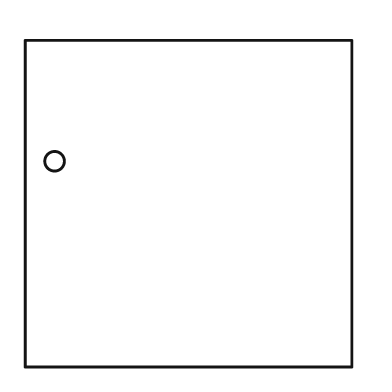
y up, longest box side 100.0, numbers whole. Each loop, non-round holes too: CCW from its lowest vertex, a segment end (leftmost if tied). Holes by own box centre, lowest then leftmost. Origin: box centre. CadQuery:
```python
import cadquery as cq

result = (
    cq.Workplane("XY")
    .moveTo(-50.0, -50.0)
    .lineTo(50.0, -50.0)
    .lineTo(50.0, 50.0)
    .lineTo(-50.0, 50.0)
    .close()
    .moveTo(-41.0, 13.0)
    .circle(3.0)
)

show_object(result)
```